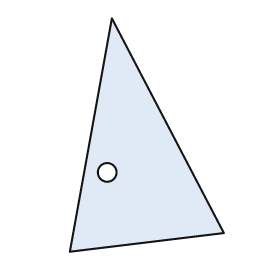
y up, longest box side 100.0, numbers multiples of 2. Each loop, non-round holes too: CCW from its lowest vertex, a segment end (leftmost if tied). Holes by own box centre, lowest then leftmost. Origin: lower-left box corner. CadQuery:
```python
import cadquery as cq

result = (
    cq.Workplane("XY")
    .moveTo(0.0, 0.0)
    .lineTo(66.0, 8.0)
    .lineTo(18.0, 100.0)
    .close()
    .moveTo(16.0, 34.0)
    .circle(4.0)
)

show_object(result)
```